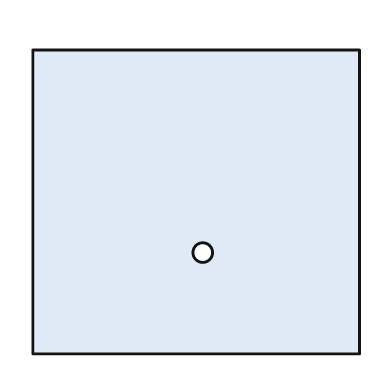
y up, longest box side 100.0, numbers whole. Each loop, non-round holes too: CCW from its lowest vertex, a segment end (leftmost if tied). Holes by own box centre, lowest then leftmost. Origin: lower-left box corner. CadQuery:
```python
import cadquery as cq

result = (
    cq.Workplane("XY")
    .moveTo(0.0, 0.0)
    .lineTo(100.0, 0.0)
    .lineTo(100.0, 93.0)
    .lineTo(0.0, 93.0)
    .close()
    .moveTo(52.0, 31.0)
    .circle(3.0)
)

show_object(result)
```